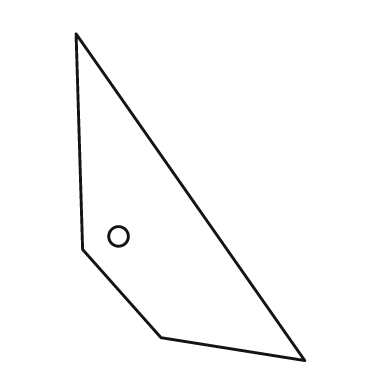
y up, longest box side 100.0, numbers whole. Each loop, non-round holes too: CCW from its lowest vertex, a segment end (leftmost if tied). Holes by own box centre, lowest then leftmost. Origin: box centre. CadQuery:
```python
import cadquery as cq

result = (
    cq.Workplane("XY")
    .moveTo(35.0, -50.0)
    .lineTo(-35.0, 50.0)
    .lineTo(-33.0, -16.0)
    .lineTo(-9.0, -43.0)
    .close()
    .moveTo(-22.0, -12.0)
    .circle(3.0)
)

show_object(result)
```